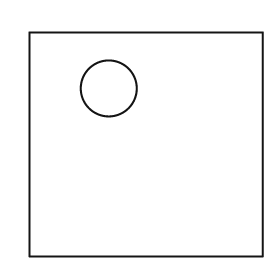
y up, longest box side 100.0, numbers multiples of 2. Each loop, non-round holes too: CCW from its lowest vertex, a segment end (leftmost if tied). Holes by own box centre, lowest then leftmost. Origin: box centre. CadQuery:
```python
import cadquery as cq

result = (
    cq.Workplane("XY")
    .moveTo(-50.0, -48.0)
    .lineTo(50.0, -48.0)
    .lineTo(50.0, 48.0)
    .lineTo(-50.0, 48.0)
    .close()
    .moveTo(-16.0, 24.0)
    .circle(12.0)
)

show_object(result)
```